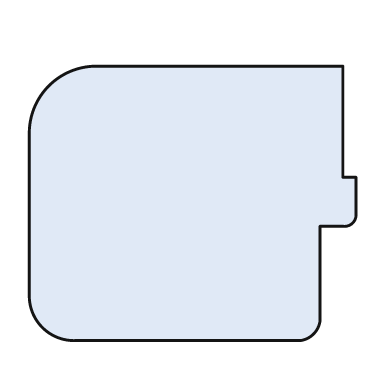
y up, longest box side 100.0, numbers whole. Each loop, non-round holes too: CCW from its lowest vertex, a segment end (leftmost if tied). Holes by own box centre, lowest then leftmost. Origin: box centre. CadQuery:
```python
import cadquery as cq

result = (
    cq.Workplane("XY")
    .moveTo(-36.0, -42.0)
    .lineTo(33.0, -42.0)
    .threePointArc((37.0, -40.0), (39.0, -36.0))
    .lineTo(39.0, -7.0)
    .lineTo(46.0, -7.0)
    .threePointArc((49.0, -6.0), (50.0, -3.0))
    .lineTo(50.0, 8.0)
    .lineTo(46.0, 8.0)
    .lineTo(46.0, 42.0)
    .lineTo(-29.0, 42.0)
    .threePointArc((-44.0, 36.0), (-50.0, 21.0))
    .lineTo(-50.0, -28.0)
    .threePointArc((-46.0, -38.0), (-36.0, -42.0))
    .close()
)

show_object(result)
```